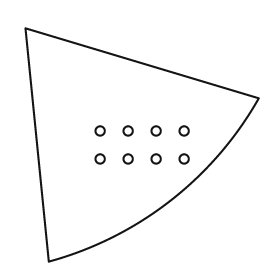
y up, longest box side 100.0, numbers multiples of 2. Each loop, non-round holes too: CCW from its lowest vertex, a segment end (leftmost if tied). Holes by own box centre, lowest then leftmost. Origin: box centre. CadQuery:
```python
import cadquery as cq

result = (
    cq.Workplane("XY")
    .moveTo(-40.0, -50.0)
    .threePointArc((12.0, -24.0), (50.0, 20.0))
    .lineTo(-50.0, 50.0)
    .close()
    .moveTo(-18.0, -6.0)
    .circle(2.0)
    .moveTo(-6.0, -6.0)
    .circle(2.0)
    .moveTo(6.0, -6.0)
    .circle(2.0)
    .moveTo(18.0, -6.0)
    .circle(2.0)
    .moveTo(-18.0, 6.0)
    .circle(2.0)
    .moveTo(-6.0, 6.0)
    .circle(2.0)
    .moveTo(6.0, 6.0)
    .circle(2.0)
    .moveTo(18.0, 6.0)
    .circle(2.0)
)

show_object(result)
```